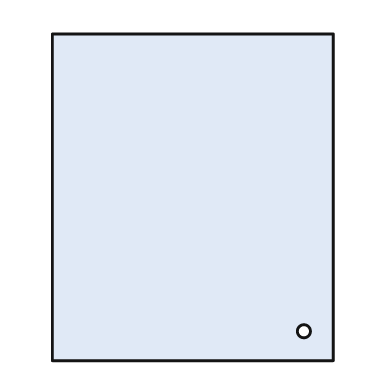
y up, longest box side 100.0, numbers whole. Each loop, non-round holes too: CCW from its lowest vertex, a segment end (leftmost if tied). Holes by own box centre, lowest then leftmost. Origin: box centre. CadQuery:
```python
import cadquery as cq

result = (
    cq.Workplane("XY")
    .moveTo(-43.0, -50.0)
    .lineTo(43.0, -50.0)
    .lineTo(43.0, 50.0)
    .lineTo(-43.0, 50.0)
    .close()
    .moveTo(34.0, -41.0)
    .circle(2.0)
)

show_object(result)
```